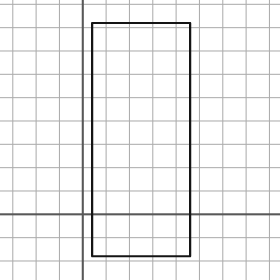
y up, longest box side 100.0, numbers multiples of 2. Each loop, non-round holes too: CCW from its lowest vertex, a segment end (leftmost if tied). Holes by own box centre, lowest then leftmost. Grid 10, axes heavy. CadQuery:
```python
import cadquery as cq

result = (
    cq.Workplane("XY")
    .moveTo(4.0, -18.0)
    .lineTo(46.0, -18.0)
    .lineTo(46.0, 82.0)
    .lineTo(4.0, 82.0)
    .close()
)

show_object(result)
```